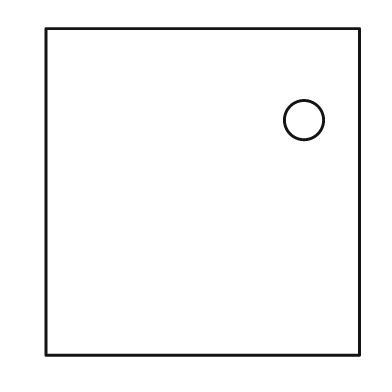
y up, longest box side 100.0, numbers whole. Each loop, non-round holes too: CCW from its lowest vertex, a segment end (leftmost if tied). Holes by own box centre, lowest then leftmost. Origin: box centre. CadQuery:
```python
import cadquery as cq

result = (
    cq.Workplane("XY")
    .moveTo(-48.0, -50.0)
    .lineTo(48.0, -50.0)
    .lineTo(48.0, 50.0)
    .lineTo(-48.0, 50.0)
    .close()
    .moveTo(31.0, 22.0)
    .circle(6.0)
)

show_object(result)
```